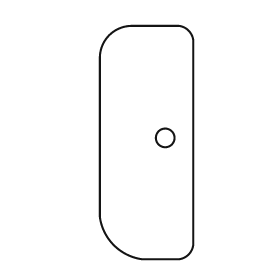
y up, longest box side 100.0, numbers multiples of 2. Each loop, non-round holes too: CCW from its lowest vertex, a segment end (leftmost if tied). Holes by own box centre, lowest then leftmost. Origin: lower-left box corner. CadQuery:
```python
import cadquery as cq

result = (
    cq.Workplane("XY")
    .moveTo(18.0, 0.0)
    .lineTo(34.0, 0.0)
    .threePointArc((38.0, 2.0), (40.0, 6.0))
    .lineTo(40.0, 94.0)
    .threePointArc((38.0, 98.0), (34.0, 100.0))
    .lineTo(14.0, 100.0)
    .threePointArc((4.0, 96.0), (0.0, 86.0))
    .lineTo(0.0, 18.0)
    .threePointArc((6.0, 6.0), (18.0, 0.0))
    .close()
    .moveTo(28.0, 52.0)
    .circle(4.0)
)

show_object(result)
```